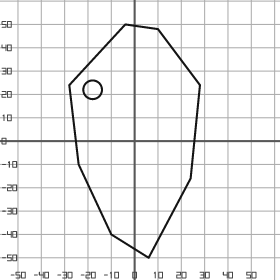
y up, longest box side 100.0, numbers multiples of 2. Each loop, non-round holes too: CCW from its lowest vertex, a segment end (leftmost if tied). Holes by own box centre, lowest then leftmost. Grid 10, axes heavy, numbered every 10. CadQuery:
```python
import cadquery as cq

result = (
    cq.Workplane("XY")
    .moveTo(6.0, -50.0)
    .lineTo(24.0, -16.0)
    .lineTo(28.0, 24.0)
    .lineTo(10.0, 48.0)
    .lineTo(-4.0, 50.0)
    .lineTo(-28.0, 24.0)
    .lineTo(-24.0, -10.0)
    .lineTo(-10.0, -40.0)
    .close()
    .moveTo(-18.0, 22.0)
    .circle(4.0)
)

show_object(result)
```